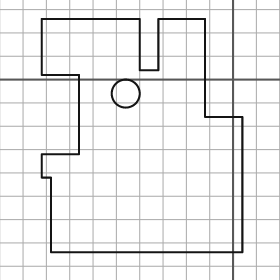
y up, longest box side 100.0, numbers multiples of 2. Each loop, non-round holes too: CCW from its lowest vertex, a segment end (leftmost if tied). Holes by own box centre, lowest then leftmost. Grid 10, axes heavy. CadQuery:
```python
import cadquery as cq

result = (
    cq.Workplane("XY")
    .moveTo(-78.0, -74.0)
    .lineTo(4.0, -74.0)
    .lineTo(4.0, -16.0)
    .lineTo(-12.0, -16.0)
    .lineTo(-12.0, 26.0)
    .lineTo(-32.0, 26.0)
    .lineTo(-32.0, 4.0)
    .lineTo(-40.0, 4.0)
    .lineTo(-40.0, 26.0)
    .lineTo(-82.0, 26.0)
    .lineTo(-82.0, 2.0)
    .lineTo(-66.0, 2.0)
    .lineTo(-66.0, -32.0)
    .lineTo(-82.0, -32.0)
    .lineTo(-82.0, -42.0)
    .lineTo(-78.0, -42.0)
    .close()
    .moveTo(-46.0, -6.0)
    .circle(6.0)
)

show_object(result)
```